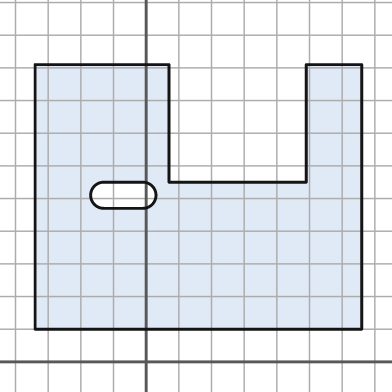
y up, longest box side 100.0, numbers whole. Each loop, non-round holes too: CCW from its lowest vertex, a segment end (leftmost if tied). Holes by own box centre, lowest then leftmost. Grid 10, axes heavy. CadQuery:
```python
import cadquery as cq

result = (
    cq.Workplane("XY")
    .moveTo(-34.0, 10.0)
    .lineTo(66.0, 10.0)
    .lineTo(66.0, 91.0)
    .lineTo(49.0, 91.0)
    .lineTo(49.0, 55.0)
    .lineTo(7.0, 55.0)
    .lineTo(7.0, 91.0)
    .lineTo(-34.0, 91.0)
    .close()
    .moveTo(-13.0, 47.0)
    .lineTo(-1.0, 47.0)
    .threePointArc((3.0, 51.0), (-1.0, 55.0))
    .lineTo(-13.0, 55.0)
    .threePointArc((-17.0, 51.0), (-13.0, 47.0))
    .close()
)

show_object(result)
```